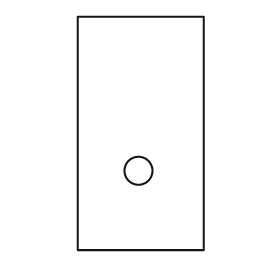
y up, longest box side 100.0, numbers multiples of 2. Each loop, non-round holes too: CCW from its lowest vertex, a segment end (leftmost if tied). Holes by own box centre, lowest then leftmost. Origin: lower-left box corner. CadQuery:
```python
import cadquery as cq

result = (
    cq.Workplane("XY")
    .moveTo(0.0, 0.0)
    .lineTo(54.0, 0.0)
    .lineTo(54.0, 100.0)
    .lineTo(0.0, 100.0)
    .close()
    .moveTo(26.0, 34.0)
    .circle(6.0)
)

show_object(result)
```